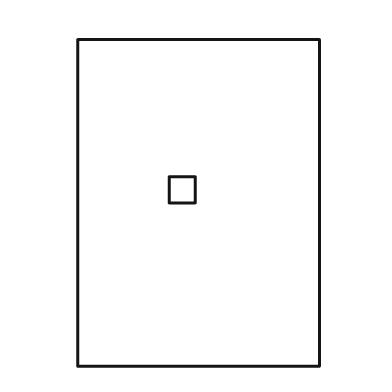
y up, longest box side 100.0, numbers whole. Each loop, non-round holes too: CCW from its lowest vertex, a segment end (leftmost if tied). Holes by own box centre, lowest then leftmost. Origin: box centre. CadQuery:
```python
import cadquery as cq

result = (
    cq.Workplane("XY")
    .moveTo(-37.0, -50.0)
    .lineTo(37.0, -50.0)
    .lineTo(37.0, 50.0)
    .lineTo(-37.0, 50.0)
    .close()
    .moveTo(-9.0, 0.0)
    .lineTo(-1.0, 0.0)
    .lineTo(-1.0, 8.0)
    .lineTo(-9.0, 8.0)
    .close()
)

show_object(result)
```